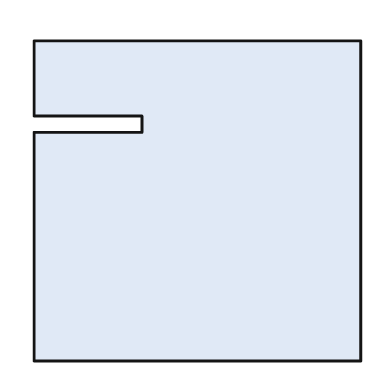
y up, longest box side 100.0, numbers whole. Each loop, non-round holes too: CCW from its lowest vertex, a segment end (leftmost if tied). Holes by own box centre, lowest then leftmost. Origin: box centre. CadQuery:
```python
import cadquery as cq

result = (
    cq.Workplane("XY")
    .moveTo(-50.0, -49.0)
    .lineTo(50.0, -49.0)
    .lineTo(50.0, 49.0)
    .lineTo(-50.0, 49.0)
    .lineTo(-50.0, 26.0)
    .lineTo(-17.0, 26.0)
    .lineTo(-17.0, 21.0)
    .lineTo(-50.0, 21.0)
    .close()
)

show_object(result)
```